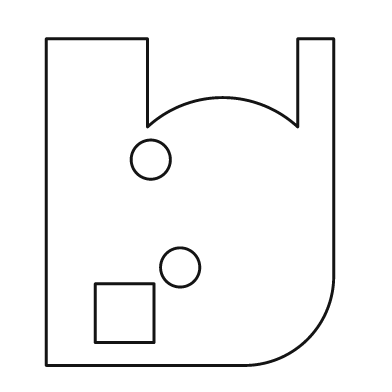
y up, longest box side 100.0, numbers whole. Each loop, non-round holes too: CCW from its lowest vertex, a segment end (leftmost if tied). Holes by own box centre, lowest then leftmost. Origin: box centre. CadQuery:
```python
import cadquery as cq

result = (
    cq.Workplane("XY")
    .moveTo(-44.0, -50.0)
    .lineTo(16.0, -50.0)
    .threePointArc((36.0, -42.0), (44.0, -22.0))
    .lineTo(44.0, 50.0)
    .lineTo(33.0, 50.0)
    .lineTo(33.0, 23.0)
    .threePointArc((10.0, 32.0), (-13.0, 23.0))
    .lineTo(-13.0, 50.0)
    .lineTo(-44.0, 50.0)
    .close()
    .moveTo(-29.0, -43.0)
    .lineTo(-11.0, -43.0)
    .lineTo(-11.0, -25.0)
    .lineTo(-29.0, -25.0)
    .close()
    .moveTo(-3.0, -20.0)
    .circle(6.0)
    .moveTo(-12.0, 13.0)
    .circle(6.0)
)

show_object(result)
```